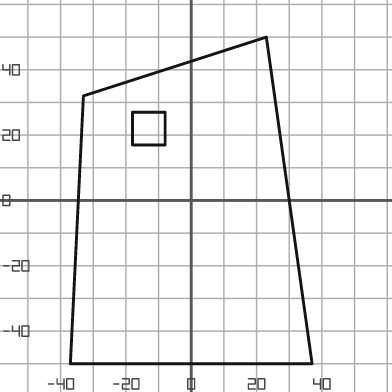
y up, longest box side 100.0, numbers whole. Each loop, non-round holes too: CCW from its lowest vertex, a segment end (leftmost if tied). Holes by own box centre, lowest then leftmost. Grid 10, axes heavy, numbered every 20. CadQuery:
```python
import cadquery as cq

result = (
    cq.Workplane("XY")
    .moveTo(-37.0, -50.0)
    .lineTo(37.0, -50.0)
    .lineTo(23.0, 50.0)
    .lineTo(-33.0, 32.0)
    .close()
    .moveTo(-18.0, 17.0)
    .lineTo(-8.0, 17.0)
    .lineTo(-8.0, 27.0)
    .lineTo(-18.0, 27.0)
    .close()
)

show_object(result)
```